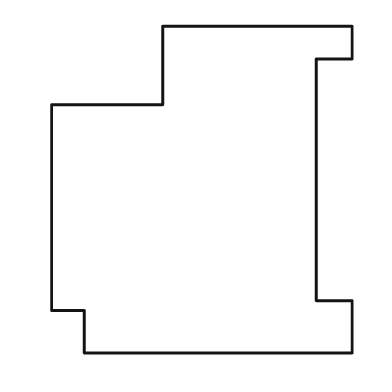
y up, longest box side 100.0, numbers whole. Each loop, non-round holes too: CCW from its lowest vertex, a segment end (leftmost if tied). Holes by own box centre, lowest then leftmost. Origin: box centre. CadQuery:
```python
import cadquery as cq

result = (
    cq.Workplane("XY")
    .moveTo(-36.0, -50.0)
    .lineTo(46.0, -50.0)
    .lineTo(46.0, -34.0)
    .lineTo(35.0, -34.0)
    .lineTo(35.0, 40.0)
    .lineTo(46.0, 40.0)
    .lineTo(46.0, 50.0)
    .lineTo(-12.0, 50.0)
    .lineTo(-12.0, 26.0)
    .lineTo(-46.0, 26.0)
    .lineTo(-46.0, -37.0)
    .lineTo(-36.0, -37.0)
    .close()
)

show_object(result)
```